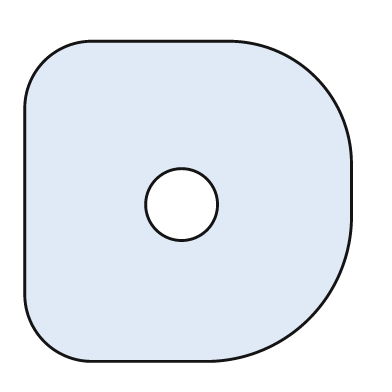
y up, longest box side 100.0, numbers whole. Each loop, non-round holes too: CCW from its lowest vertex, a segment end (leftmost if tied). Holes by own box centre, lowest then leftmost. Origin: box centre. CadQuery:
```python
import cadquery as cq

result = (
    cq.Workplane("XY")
    .moveTo(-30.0, -49.0)
    .lineTo(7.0, -49.0)
    .threePointArc((37.0, -36.0), (50.0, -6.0))
    .lineTo(50.0, 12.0)
    .threePointArc((39.0, 38.0), (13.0, 49.0))
    .lineTo(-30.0, 49.0)
    .threePointArc((-44.0, 43.0), (-50.0, 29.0))
    .lineTo(-50.0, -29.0)
    .threePointArc((-44.0, -43.0), (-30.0, -49.0))
    .close()
    .moveTo(-2.0, -1.0)
    .circle(11.0)
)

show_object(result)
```